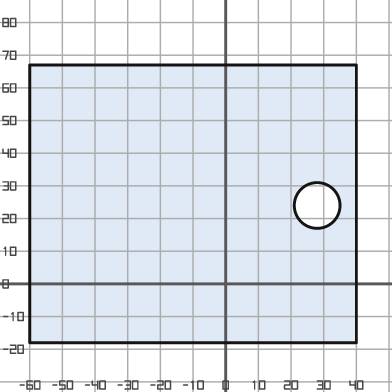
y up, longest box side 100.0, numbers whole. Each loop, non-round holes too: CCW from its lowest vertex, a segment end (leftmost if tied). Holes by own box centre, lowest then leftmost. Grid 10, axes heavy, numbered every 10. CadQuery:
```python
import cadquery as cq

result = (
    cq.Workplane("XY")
    .moveTo(-60.0, -18.0)
    .lineTo(40.0, -18.0)
    .lineTo(40.0, 67.0)
    .lineTo(-60.0, 67.0)
    .close()
    .moveTo(28.0, 24.0)
    .circle(7.0)
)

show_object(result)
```